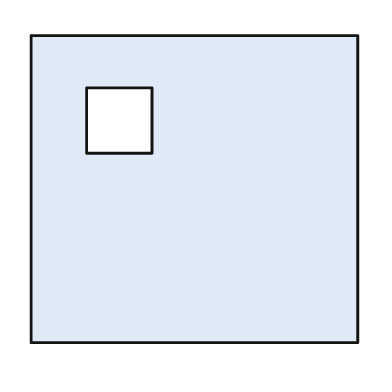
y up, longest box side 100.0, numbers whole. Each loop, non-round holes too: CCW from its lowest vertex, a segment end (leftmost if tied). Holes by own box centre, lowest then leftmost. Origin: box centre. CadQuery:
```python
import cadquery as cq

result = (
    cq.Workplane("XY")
    .moveTo(-50.0, -47.0)
    .lineTo(50.0, -47.0)
    .lineTo(50.0, 47.0)
    .lineTo(-50.0, 47.0)
    .close()
    .moveTo(-33.0, 11.0)
    .lineTo(-13.0, 11.0)
    .lineTo(-13.0, 31.0)
    .lineTo(-33.0, 31.0)
    .close()
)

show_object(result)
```